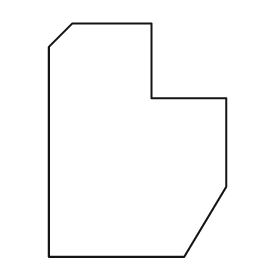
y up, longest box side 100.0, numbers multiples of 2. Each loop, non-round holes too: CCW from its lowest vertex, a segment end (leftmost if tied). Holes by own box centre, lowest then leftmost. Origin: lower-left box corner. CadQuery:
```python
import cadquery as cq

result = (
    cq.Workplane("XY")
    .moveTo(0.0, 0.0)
    .lineTo(58.0, 0.0)
    .lineTo(76.0, 30.0)
    .lineTo(76.0, 68.0)
    .lineTo(44.0, 68.0)
    .lineTo(44.0, 100.0)
    .lineTo(10.0, 100.0)
    .lineTo(0.0, 90.0)
    .close()
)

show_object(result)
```